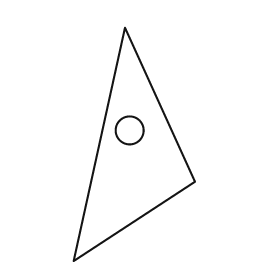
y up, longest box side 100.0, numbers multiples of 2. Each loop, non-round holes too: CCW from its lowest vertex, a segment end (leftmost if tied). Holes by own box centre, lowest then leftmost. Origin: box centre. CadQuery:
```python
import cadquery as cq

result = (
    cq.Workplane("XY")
    .moveTo(-26.0, -50.0)
    .lineTo(26.0, -16.0)
    .lineTo(-4.0, 50.0)
    .close()
    .moveTo(-2.0, 6.0)
    .circle(6.0)
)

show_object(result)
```